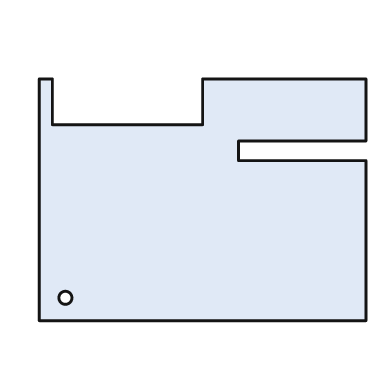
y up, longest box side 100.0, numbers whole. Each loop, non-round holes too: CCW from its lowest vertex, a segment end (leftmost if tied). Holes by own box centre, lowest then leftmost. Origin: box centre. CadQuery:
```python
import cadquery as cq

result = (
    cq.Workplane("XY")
    .moveTo(-50.0, -37.0)
    .lineTo(50.0, -37.0)
    .lineTo(50.0, 12.0)
    .lineTo(11.0, 12.0)
    .lineTo(11.0, 18.0)
    .lineTo(50.0, 18.0)
    .lineTo(50.0, 37.0)
    .lineTo(0.0, 37.0)
    .lineTo(0.0, 23.0)
    .lineTo(-46.0, 23.0)
    .lineTo(-46.0, 37.0)
    .lineTo(-50.0, 37.0)
    .close()
    .moveTo(-42.0, -30.0)
    .circle(2.0)
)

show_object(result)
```